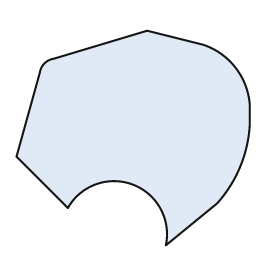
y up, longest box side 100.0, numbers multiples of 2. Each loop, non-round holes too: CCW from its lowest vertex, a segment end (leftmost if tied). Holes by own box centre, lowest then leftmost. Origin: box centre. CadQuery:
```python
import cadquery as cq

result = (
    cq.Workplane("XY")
    .moveTo(14.0, -46.0)
    .lineTo(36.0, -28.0)
    .threePointArc((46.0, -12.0), (50.0, 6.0))
    .lineTo(50.0, 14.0)
    .threePointArc((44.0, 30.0), (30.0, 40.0))
    .lineTo(6.0, 46.0)
    .lineTo(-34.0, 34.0)
    .threePointArc((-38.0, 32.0), (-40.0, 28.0))
    .lineTo(-50.0, -8.0)
    .lineTo(-28.0, -30.0)
    .threePointArc((0.0, -20.0), (14.0, -46.0))
    .close()
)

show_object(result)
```